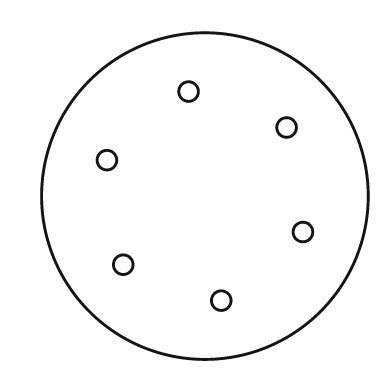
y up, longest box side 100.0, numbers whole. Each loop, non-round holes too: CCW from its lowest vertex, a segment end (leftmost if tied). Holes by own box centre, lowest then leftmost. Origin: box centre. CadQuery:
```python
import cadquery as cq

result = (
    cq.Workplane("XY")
    .moveTo(0.0, 0.0)
    .circle(50.0)
    .moveTo(5.0, -32.0)
    .circle(3.0)
    .moveTo(-25.0, -21.0)
    .circle(3.0)
    .moveTo(30.0, -11.0)
    .circle(3.0)
    .moveTo(-30.0, 11.0)
    .circle(3.0)
    .moveTo(25.0, 21.0)
    .circle(3.0)
    .moveTo(-5.0, 32.0)
    .circle(3.0)
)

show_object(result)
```